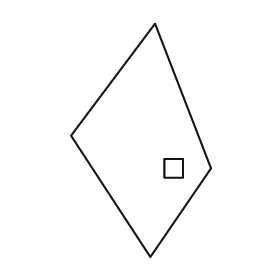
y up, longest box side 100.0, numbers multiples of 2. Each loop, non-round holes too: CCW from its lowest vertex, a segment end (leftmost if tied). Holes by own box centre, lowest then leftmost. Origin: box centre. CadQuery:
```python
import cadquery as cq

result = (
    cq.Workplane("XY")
    .moveTo(4.0, -50.0)
    .lineTo(30.0, -12.0)
    .lineTo(6.0, 50.0)
    .lineTo(-30.0, 2.0)
    .close()
    .moveTo(10.0, -16.0)
    .lineTo(18.0, -16.0)
    .lineTo(18.0, -8.0)
    .lineTo(10.0, -8.0)
    .close()
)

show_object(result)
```